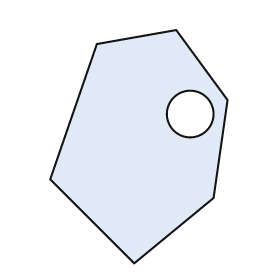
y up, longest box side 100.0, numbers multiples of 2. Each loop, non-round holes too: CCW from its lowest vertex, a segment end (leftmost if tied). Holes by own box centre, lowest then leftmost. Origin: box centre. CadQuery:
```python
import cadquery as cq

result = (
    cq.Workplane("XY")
    .moveTo(-2.0, -50.0)
    .lineTo(32.0, -22.0)
    .lineTo(38.0, 20.0)
    .lineTo(16.0, 50.0)
    .lineTo(-18.0, 44.0)
    .lineTo(-38.0, -14.0)
    .close()
    .moveTo(22.0, 14.0)
    .circle(10.0)
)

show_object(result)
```